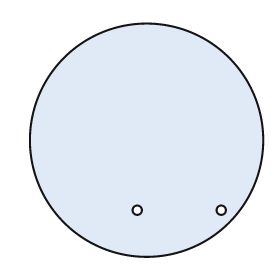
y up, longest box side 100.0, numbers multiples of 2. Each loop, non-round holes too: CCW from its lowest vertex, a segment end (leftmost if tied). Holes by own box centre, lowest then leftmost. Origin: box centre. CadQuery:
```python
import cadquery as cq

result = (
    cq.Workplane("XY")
    .moveTo(0.0, 0.0)
    .circle(50.0)
    .moveTo(-4.0, -30.0)
    .circle(2.0)
    .moveTo(32.0, -30.0)
    .circle(2.0)
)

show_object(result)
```